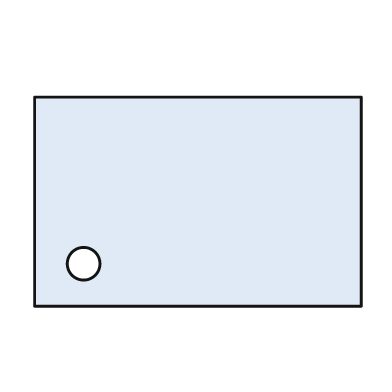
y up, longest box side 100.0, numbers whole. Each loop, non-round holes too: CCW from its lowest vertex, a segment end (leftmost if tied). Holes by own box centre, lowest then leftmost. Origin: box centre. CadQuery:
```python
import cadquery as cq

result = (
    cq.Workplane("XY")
    .moveTo(-50.0, -32.0)
    .lineTo(50.0, -32.0)
    .lineTo(50.0, 32.0)
    .lineTo(-50.0, 32.0)
    .close()
    .moveTo(-35.0, -19.0)
    .circle(5.0)
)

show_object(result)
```